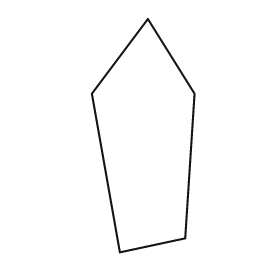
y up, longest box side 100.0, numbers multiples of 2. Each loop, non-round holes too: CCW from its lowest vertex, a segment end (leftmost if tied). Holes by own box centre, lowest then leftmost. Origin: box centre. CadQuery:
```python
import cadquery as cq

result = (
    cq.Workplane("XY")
    .moveTo(-10.0, -50.0)
    .lineTo(18.0, -44.0)
    .lineTo(22.0, 18.0)
    .lineTo(2.0, 50.0)
    .lineTo(-22.0, 18.0)
    .close()
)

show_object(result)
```